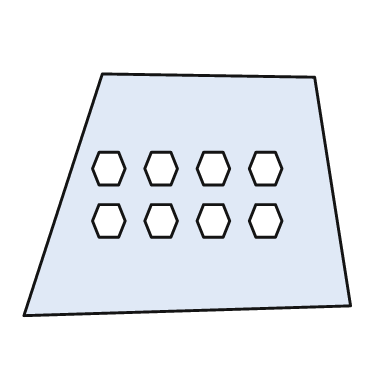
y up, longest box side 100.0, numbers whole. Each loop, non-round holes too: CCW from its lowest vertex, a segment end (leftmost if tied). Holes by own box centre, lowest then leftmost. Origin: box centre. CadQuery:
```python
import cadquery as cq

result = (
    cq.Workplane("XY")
    .moveTo(-50.0, -37.0)
    .lineTo(50.0, -34.0)
    .lineTo(39.0, 36.0)
    .lineTo(-26.0, 37.0)
    .close()
    .moveTo(-27.0, -13.0)
    .lineTo(-21.0, -13.0)
    .lineTo(-19.0, -8.0)
    .lineTo(-21.0, -3.0)
    .lineTo(-27.0, -3.0)
    .lineTo(-29.0, -8.0)
    .close()
    .moveTo(-11.0, -13.0)
    .lineTo(-5.0, -13.0)
    .lineTo(-3.0, -8.0)
    .lineTo(-5.0, -3.0)
    .lineTo(-11.0, -3.0)
    .lineTo(-13.0, -8.0)
    .close()
    .moveTo(5.0, -13.0)
    .lineTo(11.0, -13.0)
    .lineTo(13.0, -8.0)
    .lineTo(11.0, -3.0)
    .lineTo(5.0, -3.0)
    .lineTo(3.0, -8.0)
    .close()
    .moveTo(21.0, -13.0)
    .lineTo(27.0, -13.0)
    .lineTo(29.0, -8.0)
    .lineTo(27.0, -3.0)
    .lineTo(21.0, -3.0)
    .lineTo(19.0, -8.0)
    .close()
    .moveTo(-27.0, 3.0)
    .lineTo(-21.0, 3.0)
    .lineTo(-19.0, 8.0)
    .lineTo(-21.0, 13.0)
    .lineTo(-27.0, 13.0)
    .lineTo(-29.0, 8.0)
    .close()
    .moveTo(-11.0, 3.0)
    .lineTo(-5.0, 3.0)
    .lineTo(-3.0, 8.0)
    .lineTo(-5.0, 13.0)
    .lineTo(-11.0, 13.0)
    .lineTo(-13.0, 8.0)
    .close()
    .moveTo(5.0, 3.0)
    .lineTo(11.0, 3.0)
    .lineTo(13.0, 8.0)
    .lineTo(11.0, 13.0)
    .lineTo(5.0, 13.0)
    .lineTo(3.0, 8.0)
    .close()
    .moveTo(21.0, 3.0)
    .lineTo(27.0, 3.0)
    .lineTo(29.0, 8.0)
    .lineTo(27.0, 13.0)
    .lineTo(21.0, 13.0)
    .lineTo(19.0, 8.0)
    .close()
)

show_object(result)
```